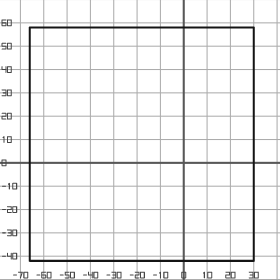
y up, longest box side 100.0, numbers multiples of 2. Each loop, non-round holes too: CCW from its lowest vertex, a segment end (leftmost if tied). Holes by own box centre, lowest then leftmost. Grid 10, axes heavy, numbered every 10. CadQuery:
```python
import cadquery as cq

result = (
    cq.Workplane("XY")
    .moveTo(-66.0, -42.0)
    .lineTo(30.0, -42.0)
    .lineTo(30.0, 58.0)
    .lineTo(-66.0, 58.0)
    .close()
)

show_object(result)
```